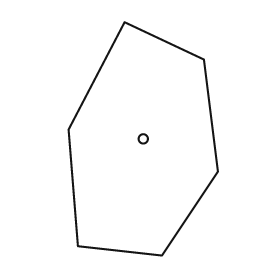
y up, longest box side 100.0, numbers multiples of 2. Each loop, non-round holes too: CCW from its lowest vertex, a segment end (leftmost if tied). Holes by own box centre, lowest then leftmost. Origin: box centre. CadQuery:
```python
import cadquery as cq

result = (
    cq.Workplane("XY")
    .moveTo(8.0, -50.0)
    .lineTo(32.0, -14.0)
    .lineTo(26.0, 34.0)
    .lineTo(-8.0, 50.0)
    .lineTo(-32.0, 4.0)
    .lineTo(-28.0, -46.0)
    .close()
    .moveTo(0.0, 0.0)
    .circle(2.0)
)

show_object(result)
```